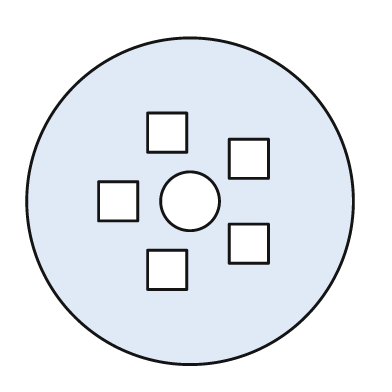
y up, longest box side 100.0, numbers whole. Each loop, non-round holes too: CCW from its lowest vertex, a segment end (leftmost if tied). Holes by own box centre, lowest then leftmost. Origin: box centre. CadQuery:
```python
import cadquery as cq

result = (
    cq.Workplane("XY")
    .moveTo(0.0, 0.0)
    .circle(50.0)
    .moveTo(-13.0, -27.0)
    .lineTo(-1.0, -27.0)
    .lineTo(-1.0, -15.0)
    .lineTo(-13.0, -15.0)
    .close()
    .moveTo(12.0, -19.0)
    .lineTo(24.0, -19.0)
    .lineTo(24.0, -7.0)
    .lineTo(12.0, -7.0)
    .close()
    .moveTo(-28.0, -6.0)
    .lineTo(-16.0, -6.0)
    .lineTo(-16.0, 6.0)
    .lineTo(-28.0, 6.0)
    .close()
    .moveTo(0.0, 0.0)
    .circle(9.0)
    .moveTo(12.0, 7.0)
    .lineTo(24.0, 7.0)
    .lineTo(24.0, 19.0)
    .lineTo(12.0, 19.0)
    .close()
    .moveTo(-13.0, 15.0)
    .lineTo(-1.0, 15.0)
    .lineTo(-1.0, 27.0)
    .lineTo(-13.0, 27.0)
    .close()
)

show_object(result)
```